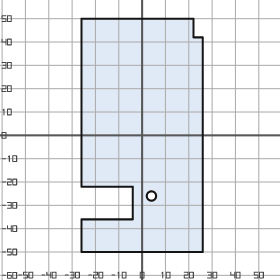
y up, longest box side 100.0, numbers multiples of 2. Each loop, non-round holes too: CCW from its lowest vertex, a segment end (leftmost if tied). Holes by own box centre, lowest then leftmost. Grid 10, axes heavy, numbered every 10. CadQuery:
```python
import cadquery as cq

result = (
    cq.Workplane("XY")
    .moveTo(-26.0, -50.0)
    .lineTo(26.0, -50.0)
    .lineTo(26.0, 42.0)
    .lineTo(22.0, 42.0)
    .lineTo(22.0, 50.0)
    .lineTo(-26.0, 50.0)
    .lineTo(-26.0, -22.0)
    .lineTo(-4.0, -22.0)
    .lineTo(-4.0, -36.0)
    .lineTo(-26.0, -36.0)
    .close()
    .moveTo(4.0, -26.0)
    .circle(2.0)
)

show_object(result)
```